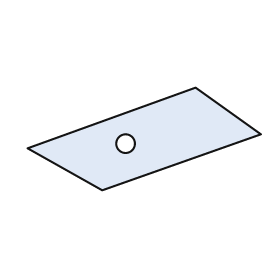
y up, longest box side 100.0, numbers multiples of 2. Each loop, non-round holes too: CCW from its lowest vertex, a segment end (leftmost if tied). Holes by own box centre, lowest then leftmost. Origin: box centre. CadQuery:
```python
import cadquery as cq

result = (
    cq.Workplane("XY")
    .moveTo(-18.0, -22.0)
    .lineTo(50.0, 2.0)
    .lineTo(22.0, 22.0)
    .lineTo(-50.0, -4.0)
    .close()
    .moveTo(-8.0, -2.0)
    .circle(4.0)
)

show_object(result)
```